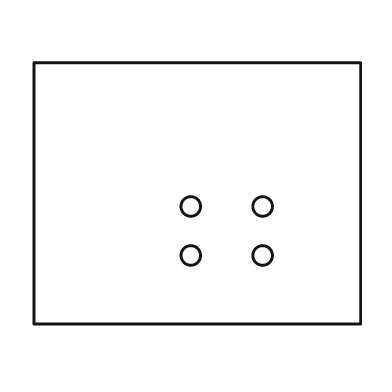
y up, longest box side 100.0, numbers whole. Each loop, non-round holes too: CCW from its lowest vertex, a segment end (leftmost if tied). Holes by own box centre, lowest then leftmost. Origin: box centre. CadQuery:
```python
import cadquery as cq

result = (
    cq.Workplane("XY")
    .moveTo(-50.0, -40.0)
    .lineTo(50.0, -40.0)
    .lineTo(50.0, 40.0)
    .lineTo(-50.0, 40.0)
    .close()
    .moveTo(-2.0, -19.0)
    .circle(3.0)
    .moveTo(20.0, -19.0)
    .circle(3.0)
    .moveTo(-2.0, -4.0)
    .circle(3.0)
    .moveTo(20.0, -4.0)
    .circle(3.0)
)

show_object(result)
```